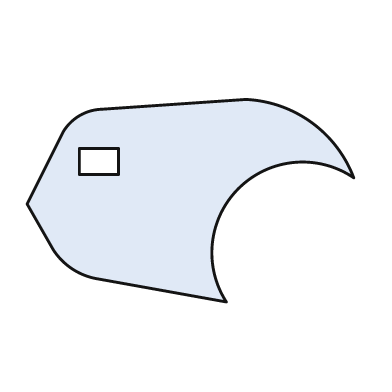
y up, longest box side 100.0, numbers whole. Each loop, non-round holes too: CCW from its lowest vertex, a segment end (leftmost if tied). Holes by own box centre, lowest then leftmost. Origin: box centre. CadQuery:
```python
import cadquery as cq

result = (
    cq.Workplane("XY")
    .moveTo(11.0, -31.0)
    .threePointArc((15.0, 4.0), (50.0, 7.0))
    .threePointArc((37.0, 24.0), (17.0, 31.0))
    .lineTo(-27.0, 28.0)
    .threePointArc((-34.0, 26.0), (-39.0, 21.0))
    .lineTo(-50.0, -1.0)
    .lineTo(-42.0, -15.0)
    .threePointArc((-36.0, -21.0), (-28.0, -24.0))
    .close()
    .moveTo(-34.0, 8.0)
    .lineTo(-22.0, 8.0)
    .lineTo(-22.0, 16.0)
    .lineTo(-34.0, 16.0)
    .close()
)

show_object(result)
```